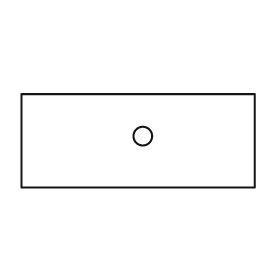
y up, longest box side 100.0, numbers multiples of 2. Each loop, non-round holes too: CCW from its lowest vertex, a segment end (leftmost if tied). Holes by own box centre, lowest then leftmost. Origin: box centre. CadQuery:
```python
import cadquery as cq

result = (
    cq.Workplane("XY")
    .moveTo(-50.0, -20.0)
    .lineTo(50.0, -20.0)
    .lineTo(50.0, 20.0)
    .lineTo(-50.0, 20.0)
    .close()
    .moveTo(2.0, 2.0)
    .circle(4.0)
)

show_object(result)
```